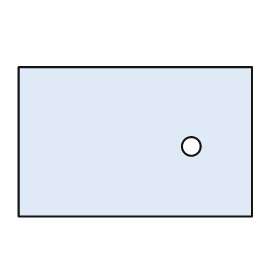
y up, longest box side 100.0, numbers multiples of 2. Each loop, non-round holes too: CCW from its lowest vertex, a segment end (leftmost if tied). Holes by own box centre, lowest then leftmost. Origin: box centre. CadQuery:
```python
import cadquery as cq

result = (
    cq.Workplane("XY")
    .moveTo(-50.0, -32.0)
    .lineTo(50.0, -32.0)
    .lineTo(50.0, 32.0)
    .lineTo(-50.0, 32.0)
    .close()
    .moveTo(24.0, -2.0)
    .circle(4.0)
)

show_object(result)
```